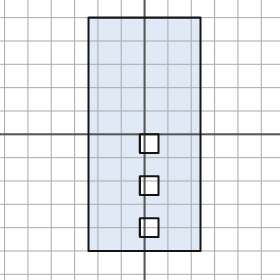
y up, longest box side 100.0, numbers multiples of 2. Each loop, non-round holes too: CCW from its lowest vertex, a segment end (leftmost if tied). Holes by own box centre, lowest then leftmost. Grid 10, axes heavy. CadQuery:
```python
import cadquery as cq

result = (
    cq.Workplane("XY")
    .moveTo(-24.0, -50.0)
    .lineTo(24.0, -50.0)
    .lineTo(24.0, 50.0)
    .lineTo(-24.0, 50.0)
    .close()
    .moveTo(-2.0, -44.0)
    .lineTo(6.0, -44.0)
    .lineTo(6.0, -36.0)
    .lineTo(-2.0, -36.0)
    .close()
    .moveTo(-2.0, -26.0)
    .lineTo(6.0, -26.0)
    .lineTo(6.0, -18.0)
    .lineTo(-2.0, -18.0)
    .close()
    .moveTo(-2.0, -8.0)
    .lineTo(6.0, -8.0)
    .lineTo(6.0, 0.0)
    .lineTo(-2.0, 0.0)
    .close()
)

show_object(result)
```